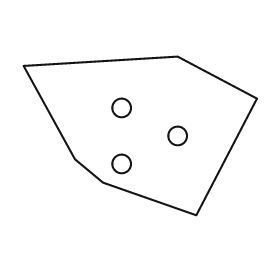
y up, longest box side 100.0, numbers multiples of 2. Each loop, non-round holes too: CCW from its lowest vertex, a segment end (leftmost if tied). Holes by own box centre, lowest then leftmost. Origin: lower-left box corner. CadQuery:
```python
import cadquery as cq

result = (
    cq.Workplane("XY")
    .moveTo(74.0, 0.0)
    .lineTo(100.0, 50.0)
    .lineTo(66.0, 68.0)
    .lineTo(0.0, 64.0)
    .lineTo(22.0, 24.0)
    .lineTo(34.0, 14.0)
    .close()
    .moveTo(42.0, 22.0)
    .circle(4.0)
    .moveTo(66.0, 34.0)
    .circle(4.0)
    .moveTo(42.0, 46.0)
    .circle(4.0)
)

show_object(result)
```